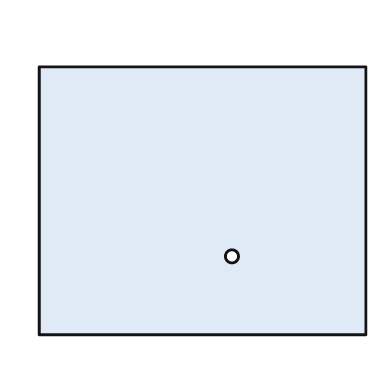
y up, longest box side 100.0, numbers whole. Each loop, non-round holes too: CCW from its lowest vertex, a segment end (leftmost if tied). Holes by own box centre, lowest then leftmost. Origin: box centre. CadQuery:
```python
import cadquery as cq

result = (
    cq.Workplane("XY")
    .moveTo(-50.0, -41.0)
    .lineTo(50.0, -41.0)
    .lineTo(50.0, 41.0)
    .lineTo(-50.0, 41.0)
    .close()
    .moveTo(9.0, -17.0)
    .circle(2.0)
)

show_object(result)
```